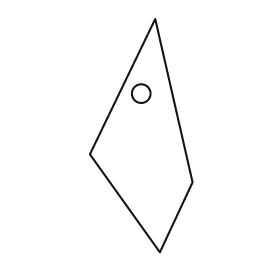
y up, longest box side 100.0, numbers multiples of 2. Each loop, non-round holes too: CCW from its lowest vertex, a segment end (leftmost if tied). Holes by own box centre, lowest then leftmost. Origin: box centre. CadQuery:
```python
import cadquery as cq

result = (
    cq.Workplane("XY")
    .moveTo(8.0, -50.0)
    .lineTo(22.0, -20.0)
    .lineTo(6.0, 50.0)
    .lineTo(-22.0, -8.0)
    .close()
    .moveTo(0.0, 18.0)
    .circle(4.0)
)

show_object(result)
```